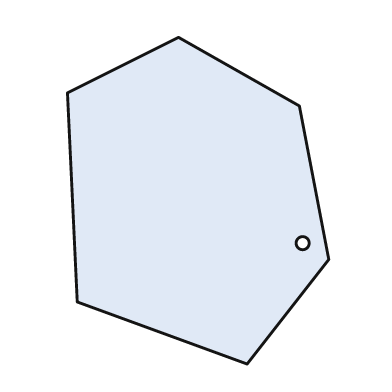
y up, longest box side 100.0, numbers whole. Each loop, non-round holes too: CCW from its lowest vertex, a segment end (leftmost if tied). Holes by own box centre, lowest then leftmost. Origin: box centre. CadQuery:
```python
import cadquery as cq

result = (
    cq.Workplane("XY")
    .moveTo(15.0, -50.0)
    .lineTo(40.0, -18.0)
    .lineTo(31.0, 29.0)
    .lineTo(-6.0, 50.0)
    .lineTo(-40.0, 33.0)
    .lineTo(-37.0, -31.0)
    .close()
    .moveTo(32.0, -13.0)
    .circle(2.0)
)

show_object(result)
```